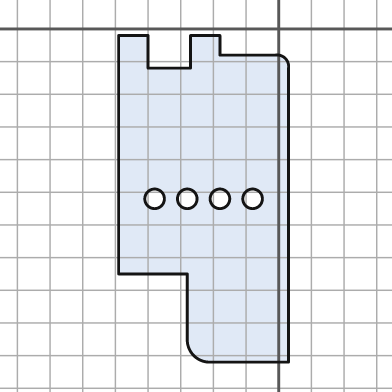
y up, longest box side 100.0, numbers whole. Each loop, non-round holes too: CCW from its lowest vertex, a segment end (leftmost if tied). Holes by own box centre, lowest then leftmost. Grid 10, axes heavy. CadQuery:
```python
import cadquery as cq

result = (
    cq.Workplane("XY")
    .moveTo(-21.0, -102.0)
    .lineTo(3.0, -102.0)
    .lineTo(3.0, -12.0)
    .threePointArc((2.0, -9.0), (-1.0, -8.0))
    .lineTo(-18.0, -8.0)
    .lineTo(-18.0, -2.0)
    .lineTo(-27.0, -2.0)
    .lineTo(-27.0, -12.0)
    .lineTo(-40.0, -12.0)
    .lineTo(-40.0, -2.0)
    .lineTo(-49.0, -2.0)
    .lineTo(-49.0, -75.0)
    .lineTo(-28.0, -75.0)
    .lineTo(-28.0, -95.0)
    .threePointArc((-26.0, -100.0), (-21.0, -102.0))
    .close()
    .moveTo(-38.0, -52.0)
    .circle(3.0)
    .moveTo(-28.0, -52.0)
    .circle(3.0)
    .moveTo(-18.0, -52.0)
    .circle(3.0)
    .moveTo(-8.0, -52.0)
    .circle(3.0)
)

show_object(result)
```